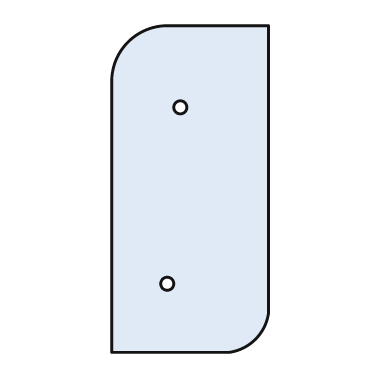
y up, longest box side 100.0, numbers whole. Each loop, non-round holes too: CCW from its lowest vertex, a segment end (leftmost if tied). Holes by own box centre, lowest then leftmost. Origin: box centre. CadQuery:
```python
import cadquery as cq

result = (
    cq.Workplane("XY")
    .moveTo(-24.0, -50.0)
    .lineTo(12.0, -50.0)
    .threePointArc((20.0, -46.0), (24.0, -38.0))
    .lineTo(24.0, 50.0)
    .lineTo(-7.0, 50.0)
    .threePointArc((-19.0, 45.0), (-24.0, 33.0))
    .close()
    .moveTo(-7.0, -29.0)
    .circle(2.0)
    .moveTo(-3.0, 25.0)
    .circle(2.0)
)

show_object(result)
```